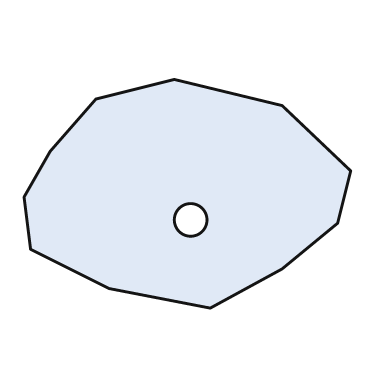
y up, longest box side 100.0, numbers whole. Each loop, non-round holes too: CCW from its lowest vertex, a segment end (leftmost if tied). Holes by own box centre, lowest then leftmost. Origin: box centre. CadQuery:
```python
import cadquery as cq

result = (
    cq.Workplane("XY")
    .moveTo(7.0, -35.0)
    .lineTo(29.0, -23.0)
    .lineTo(46.0, -9.0)
    .lineTo(50.0, 7.0)
    .lineTo(29.0, 27.0)
    .lineTo(-4.0, 35.0)
    .lineTo(-28.0, 29.0)
    .lineTo(-42.0, 13.0)
    .lineTo(-50.0, -1.0)
    .lineTo(-48.0, -17.0)
    .lineTo(-24.0, -29.0)
    .close()
    .moveTo(1.0, -8.0)
    .circle(5.0)
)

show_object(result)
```